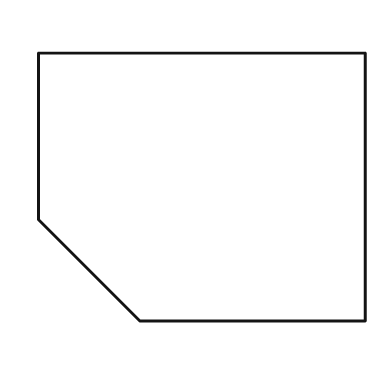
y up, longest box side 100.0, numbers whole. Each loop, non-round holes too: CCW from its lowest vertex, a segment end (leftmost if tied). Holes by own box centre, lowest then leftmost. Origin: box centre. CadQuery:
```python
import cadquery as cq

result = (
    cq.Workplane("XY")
    .moveTo(-19.0, -41.0)
    .lineTo(50.0, -41.0)
    .lineTo(50.0, 41.0)
    .lineTo(-50.0, 41.0)
    .lineTo(-50.0, -10.0)
    .close()
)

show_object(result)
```